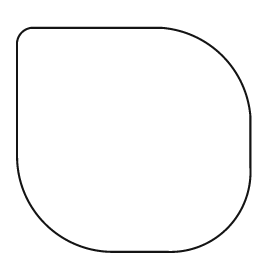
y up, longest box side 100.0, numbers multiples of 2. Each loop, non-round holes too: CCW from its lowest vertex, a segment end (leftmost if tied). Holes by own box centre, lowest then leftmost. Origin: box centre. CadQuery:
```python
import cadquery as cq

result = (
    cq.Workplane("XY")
    .moveTo(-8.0, -48.0)
    .lineTo(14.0, -48.0)
    .threePointArc((40.0, -38.0), (50.0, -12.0))
    .lineTo(50.0, 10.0)
    .threePointArc((38.0, 36.0), (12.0, 48.0))
    .lineTo(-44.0, 48.0)
    .threePointArc((-48.0, 46.0), (-50.0, 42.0))
    .lineTo(-50.0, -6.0)
    .threePointArc((-38.0, -36.0), (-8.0, -48.0))
    .close()
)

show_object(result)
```